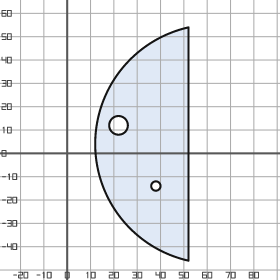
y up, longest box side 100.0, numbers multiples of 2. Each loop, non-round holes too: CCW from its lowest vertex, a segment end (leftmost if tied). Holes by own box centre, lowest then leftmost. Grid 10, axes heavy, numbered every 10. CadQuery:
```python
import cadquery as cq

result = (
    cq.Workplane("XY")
    .moveTo(52.0, -46.0)
    .lineTo(52.0, 54.0)
    .threePointArc((12.0, 4.0), (52.0, -46.0))
    .close()
    .moveTo(38.0, -14.0)
    .circle(2.0)
    .moveTo(22.0, 12.0)
    .circle(4.0)
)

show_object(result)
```